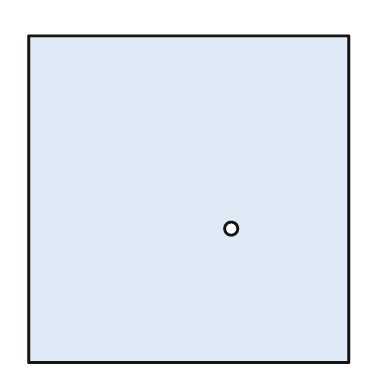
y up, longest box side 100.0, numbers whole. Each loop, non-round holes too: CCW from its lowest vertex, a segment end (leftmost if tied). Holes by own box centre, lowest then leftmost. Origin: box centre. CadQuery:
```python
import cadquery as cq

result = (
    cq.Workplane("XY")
    .moveTo(-49.0, -50.0)
    .lineTo(49.0, -50.0)
    .lineTo(49.0, 50.0)
    .lineTo(-49.0, 50.0)
    .close()
    .moveTo(13.0, -9.0)
    .circle(2.0)
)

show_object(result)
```